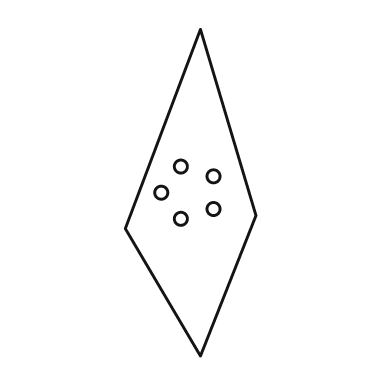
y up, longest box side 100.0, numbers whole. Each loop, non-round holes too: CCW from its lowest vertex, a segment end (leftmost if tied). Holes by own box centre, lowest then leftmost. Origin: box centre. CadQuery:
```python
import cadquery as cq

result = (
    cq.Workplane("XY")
    .moveTo(3.0, -50.0)
    .lineTo(20.0, -7.0)
    .lineTo(3.0, 50.0)
    .lineTo(-20.0, -11.0)
    .close()
    .moveTo(-3.0, -8.0)
    .circle(2.0)
    .moveTo(7.0, -5.0)
    .circle(2.0)
    .moveTo(-9.0, 0.0)
    .circle(2.0)
    .moveTo(7.0, 5.0)
    .circle(2.0)
    .moveTo(-3.0, 8.0)
    .circle(2.0)
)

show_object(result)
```